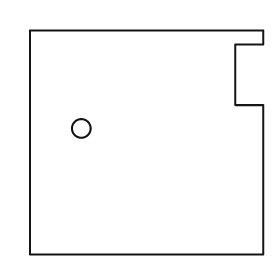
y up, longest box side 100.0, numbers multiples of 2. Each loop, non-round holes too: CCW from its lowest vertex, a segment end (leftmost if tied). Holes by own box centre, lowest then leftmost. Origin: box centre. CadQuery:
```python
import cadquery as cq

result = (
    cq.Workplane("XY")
    .moveTo(-50.0, -48.0)
    .lineTo(50.0, -48.0)
    .lineTo(50.0, 16.0)
    .lineTo(38.0, 16.0)
    .lineTo(38.0, 42.0)
    .lineTo(50.0, 42.0)
    .lineTo(50.0, 48.0)
    .lineTo(-50.0, 48.0)
    .close()
    .moveTo(-28.0, 6.0)
    .circle(4.0)
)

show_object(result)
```